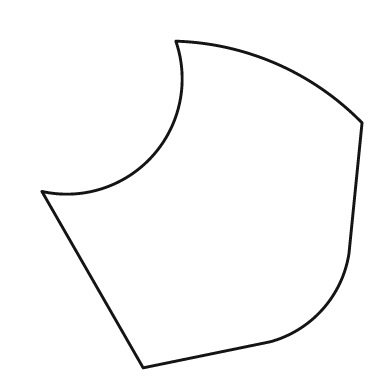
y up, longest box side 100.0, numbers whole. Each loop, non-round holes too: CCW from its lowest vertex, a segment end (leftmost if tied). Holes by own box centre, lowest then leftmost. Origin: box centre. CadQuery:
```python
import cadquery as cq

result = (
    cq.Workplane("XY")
    .moveTo(-18.0, -50.0)
    .lineTo(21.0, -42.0)
    .threePointArc((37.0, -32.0), (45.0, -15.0))
    .lineTo(49.0, 25.0)
    .threePointArc((23.0, 43.0), (-8.0, 50.0))
    .threePointArc((-15.0, 15.0), (-49.0, 4.0))
    .close()
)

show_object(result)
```